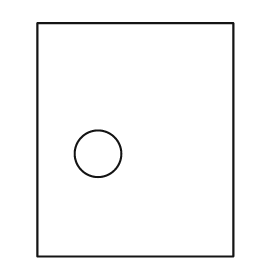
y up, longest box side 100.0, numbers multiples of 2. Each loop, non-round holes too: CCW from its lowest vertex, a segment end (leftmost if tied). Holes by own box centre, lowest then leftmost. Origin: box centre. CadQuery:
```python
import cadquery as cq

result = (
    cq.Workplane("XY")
    .moveTo(-42.0, -50.0)
    .lineTo(42.0, -50.0)
    .lineTo(42.0, 50.0)
    .lineTo(-42.0, 50.0)
    .close()
    .moveTo(-16.0, -6.0)
    .circle(10.0)
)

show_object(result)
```